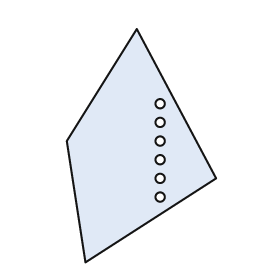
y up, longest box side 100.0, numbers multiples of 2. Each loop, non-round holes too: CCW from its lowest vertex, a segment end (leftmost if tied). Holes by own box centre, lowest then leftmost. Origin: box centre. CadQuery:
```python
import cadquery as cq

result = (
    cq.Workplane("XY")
    .moveTo(-24.0, -50.0)
    .lineTo(32.0, -14.0)
    .lineTo(-2.0, 50.0)
    .lineTo(-32.0, 2.0)
    .close()
    .moveTo(8.0, -22.0)
    .circle(2.0)
    .moveTo(8.0, -14.0)
    .circle(2.0)
    .moveTo(8.0, -6.0)
    .circle(2.0)
    .moveTo(8.0, 2.0)
    .circle(2.0)
    .moveTo(8.0, 10.0)
    .circle(2.0)
    .moveTo(8.0, 18.0)
    .circle(2.0)
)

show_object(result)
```